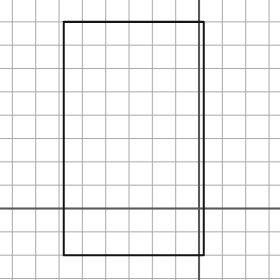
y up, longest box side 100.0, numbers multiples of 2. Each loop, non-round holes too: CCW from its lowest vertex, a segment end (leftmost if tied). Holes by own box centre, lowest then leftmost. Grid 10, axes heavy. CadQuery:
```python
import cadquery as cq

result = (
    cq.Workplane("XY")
    .moveTo(-58.0, -20.0)
    .lineTo(2.0, -20.0)
    .lineTo(2.0, 80.0)
    .lineTo(-58.0, 80.0)
    .close()
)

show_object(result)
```